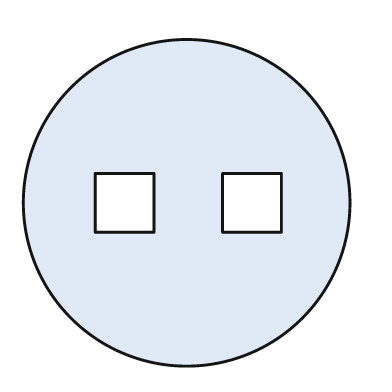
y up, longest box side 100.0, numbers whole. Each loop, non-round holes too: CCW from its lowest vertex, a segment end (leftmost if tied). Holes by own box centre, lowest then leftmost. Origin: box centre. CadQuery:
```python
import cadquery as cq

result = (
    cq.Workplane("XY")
    .moveTo(0.0, 0.0)
    .circle(50.0)
    .moveTo(-28.0, -9.0)
    .lineTo(-10.0, -9.0)
    .lineTo(-10.0, 9.0)
    .lineTo(-28.0, 9.0)
    .close()
    .moveTo(11.0, -9.0)
    .lineTo(29.0, -9.0)
    .lineTo(29.0, 9.0)
    .lineTo(11.0, 9.0)
    .close()
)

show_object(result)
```